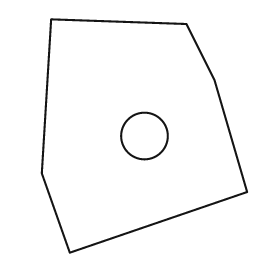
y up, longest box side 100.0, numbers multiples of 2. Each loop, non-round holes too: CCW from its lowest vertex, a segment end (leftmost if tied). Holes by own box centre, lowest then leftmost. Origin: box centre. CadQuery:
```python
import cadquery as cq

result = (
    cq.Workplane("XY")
    .moveTo(-32.0, -50.0)
    .lineTo(44.0, -24.0)
    .lineTo(30.0, 24.0)
    .lineTo(18.0, 48.0)
    .lineTo(-40.0, 50.0)
    .lineTo(-44.0, -16.0)
    .close()
    .moveTo(0.0, 0.0)
    .circle(10.0)
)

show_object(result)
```